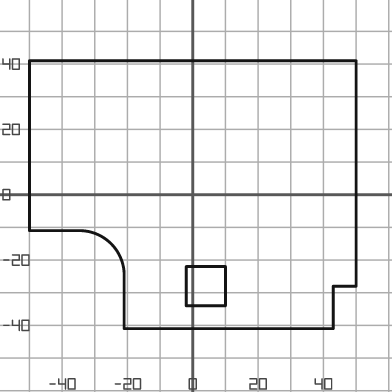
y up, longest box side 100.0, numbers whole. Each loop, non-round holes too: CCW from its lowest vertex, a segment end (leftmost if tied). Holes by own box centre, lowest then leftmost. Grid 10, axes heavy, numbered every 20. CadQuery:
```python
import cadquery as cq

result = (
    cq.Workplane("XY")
    .moveTo(-21.0, -41.0)
    .lineTo(43.0, -41.0)
    .lineTo(43.0, -28.0)
    .lineTo(50.0, -28.0)
    .lineTo(50.0, 41.0)
    .lineTo(-50.0, 41.0)
    .lineTo(-50.0, -11.0)
    .lineTo(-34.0, -11.0)
    .threePointArc((-25.0, -15.0), (-21.0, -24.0))
    .close()
    .moveTo(-2.0, -34.0)
    .lineTo(10.0, -34.0)
    .lineTo(10.0, -22.0)
    .lineTo(-2.0, -22.0)
    .close()
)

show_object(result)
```